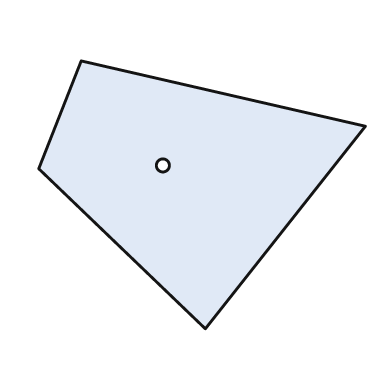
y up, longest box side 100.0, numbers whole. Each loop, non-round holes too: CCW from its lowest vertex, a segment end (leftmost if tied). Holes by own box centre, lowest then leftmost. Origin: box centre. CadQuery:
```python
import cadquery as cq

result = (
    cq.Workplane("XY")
    .moveTo(1.0, -41.0)
    .lineTo(50.0, 21.0)
    .lineTo(-37.0, 41.0)
    .lineTo(-50.0, 8.0)
    .close()
    .moveTo(-12.0, 9.0)
    .circle(2.0)
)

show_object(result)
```